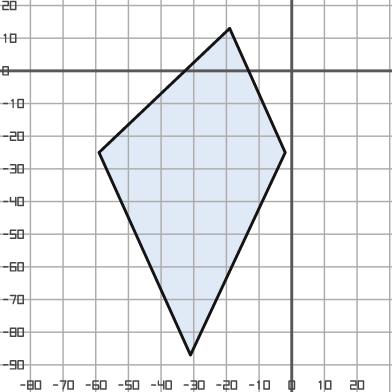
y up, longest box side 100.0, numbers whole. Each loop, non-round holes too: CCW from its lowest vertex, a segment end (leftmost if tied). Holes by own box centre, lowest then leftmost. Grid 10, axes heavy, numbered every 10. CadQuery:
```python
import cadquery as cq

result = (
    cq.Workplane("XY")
    .moveTo(-31.0, -87.0)
    .lineTo(-2.0, -25.0)
    .lineTo(-19.0, 13.0)
    .lineTo(-59.0, -25.0)
    .close()
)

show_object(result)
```